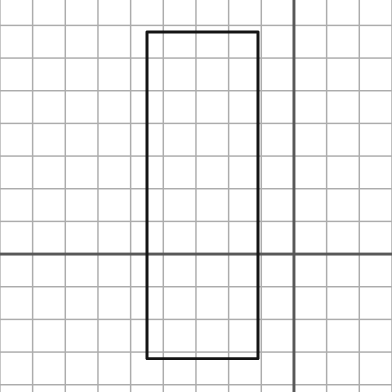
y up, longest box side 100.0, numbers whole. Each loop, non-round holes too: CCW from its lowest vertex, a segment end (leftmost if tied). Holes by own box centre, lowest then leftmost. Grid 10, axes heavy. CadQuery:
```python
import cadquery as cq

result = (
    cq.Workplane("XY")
    .moveTo(-45.0, -32.0)
    .lineTo(-11.0, -32.0)
    .lineTo(-11.0, 68.0)
    .lineTo(-45.0, 68.0)
    .close()
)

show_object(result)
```